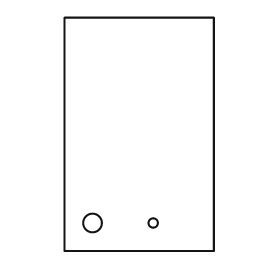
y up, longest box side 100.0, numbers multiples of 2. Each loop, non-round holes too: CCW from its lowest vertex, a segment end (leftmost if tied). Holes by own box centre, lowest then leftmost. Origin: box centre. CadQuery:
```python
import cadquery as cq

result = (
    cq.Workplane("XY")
    .moveTo(-32.0, -50.0)
    .lineTo(32.0, -50.0)
    .lineTo(32.0, 50.0)
    .lineTo(-32.0, 50.0)
    .close()
    .moveTo(-20.0, -38.0)
    .circle(4.0)
    .moveTo(6.0, -38.0)
    .circle(2.0)
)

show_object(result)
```